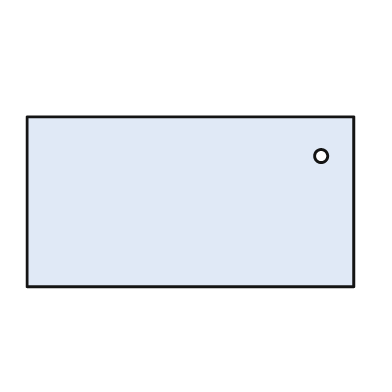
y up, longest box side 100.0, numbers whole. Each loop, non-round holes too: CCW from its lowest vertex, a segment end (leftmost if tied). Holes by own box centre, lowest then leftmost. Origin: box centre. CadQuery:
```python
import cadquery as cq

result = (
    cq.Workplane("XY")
    .moveTo(-50.0, -26.0)
    .lineTo(50.0, -26.0)
    .lineTo(50.0, 26.0)
    .lineTo(-50.0, 26.0)
    .close()
    .moveTo(40.0, 14.0)
    .circle(2.0)
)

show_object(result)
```